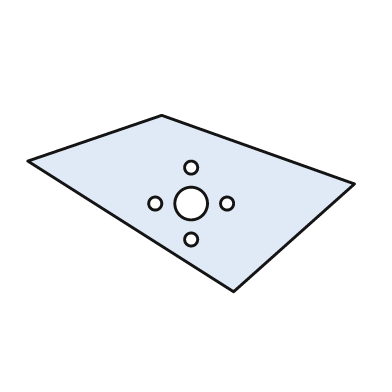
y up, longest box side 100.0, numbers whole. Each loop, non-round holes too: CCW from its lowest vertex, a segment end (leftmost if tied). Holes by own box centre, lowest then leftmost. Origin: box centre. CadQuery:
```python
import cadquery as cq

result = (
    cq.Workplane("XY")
    .moveTo(13.0, -27.0)
    .lineTo(50.0, 6.0)
    .lineTo(-9.0, 27.0)
    .lineTo(-50.0, 13.0)
    .close()
    .moveTo(0.0, -11.0)
    .circle(2.0)
    .moveTo(-11.0, 0.0)
    .circle(2.0)
    .moveTo(0.0, 0.0)
    .circle(5.0)
    .moveTo(11.0, 0.0)
    .circle(2.0)
    .moveTo(0.0, 11.0)
    .circle(2.0)
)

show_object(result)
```